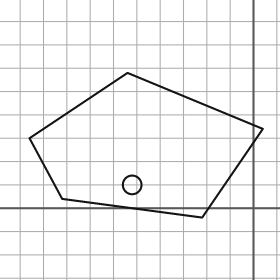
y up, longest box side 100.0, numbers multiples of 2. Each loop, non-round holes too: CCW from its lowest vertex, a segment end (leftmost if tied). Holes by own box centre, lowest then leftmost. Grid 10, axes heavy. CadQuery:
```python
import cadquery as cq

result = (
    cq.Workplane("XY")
    .moveTo(-22.0, -4.0)
    .lineTo(4.0, 34.0)
    .lineTo(-54.0, 58.0)
    .lineTo(-96.0, 30.0)
    .lineTo(-82.0, 4.0)
    .close()
    .moveTo(-52.0, 10.0)
    .circle(4.0)
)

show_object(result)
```